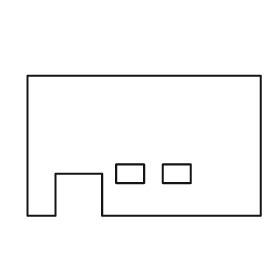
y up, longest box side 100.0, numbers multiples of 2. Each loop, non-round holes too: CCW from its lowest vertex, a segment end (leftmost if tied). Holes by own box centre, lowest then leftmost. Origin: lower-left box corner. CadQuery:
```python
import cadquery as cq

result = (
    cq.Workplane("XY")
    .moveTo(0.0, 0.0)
    .lineTo(12.0, 0.0)
    .lineTo(12.0, 18.0)
    .lineTo(32.0, 18.0)
    .lineTo(32.0, 0.0)
    .lineTo(100.0, 0.0)
    .lineTo(100.0, 60.0)
    .lineTo(0.0, 60.0)
    .close()
    .moveTo(38.0, 14.0)
    .lineTo(50.0, 14.0)
    .lineTo(50.0, 22.0)
    .lineTo(38.0, 22.0)
    .close()
    .moveTo(58.0, 14.0)
    .lineTo(70.0, 14.0)
    .lineTo(70.0, 22.0)
    .lineTo(58.0, 22.0)
    .close()
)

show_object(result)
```